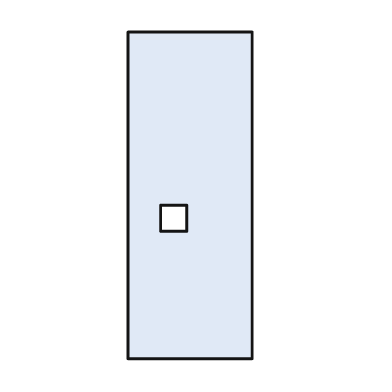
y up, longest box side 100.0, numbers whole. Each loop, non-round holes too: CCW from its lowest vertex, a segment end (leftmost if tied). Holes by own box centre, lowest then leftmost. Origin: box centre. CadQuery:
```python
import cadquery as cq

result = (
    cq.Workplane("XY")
    .moveTo(-19.0, -50.0)
    .lineTo(19.0, -50.0)
    .lineTo(19.0, 50.0)
    .lineTo(-19.0, 50.0)
    .close()
    .moveTo(-9.0, -11.0)
    .lineTo(-1.0, -11.0)
    .lineTo(-1.0, -3.0)
    .lineTo(-9.0, -3.0)
    .close()
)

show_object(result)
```